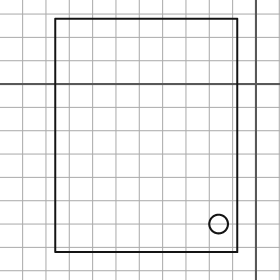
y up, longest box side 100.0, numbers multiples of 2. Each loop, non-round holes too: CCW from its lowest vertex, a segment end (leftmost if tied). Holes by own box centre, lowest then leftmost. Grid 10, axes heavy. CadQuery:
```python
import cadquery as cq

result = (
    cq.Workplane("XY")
    .moveTo(-86.0, -72.0)
    .lineTo(-8.0, -72.0)
    .lineTo(-8.0, 28.0)
    .lineTo(-86.0, 28.0)
    .close()
    .moveTo(-16.0, -60.0)
    .circle(4.0)
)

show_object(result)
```